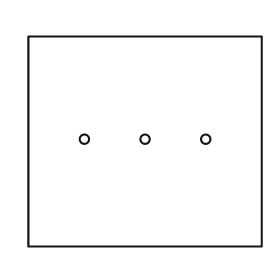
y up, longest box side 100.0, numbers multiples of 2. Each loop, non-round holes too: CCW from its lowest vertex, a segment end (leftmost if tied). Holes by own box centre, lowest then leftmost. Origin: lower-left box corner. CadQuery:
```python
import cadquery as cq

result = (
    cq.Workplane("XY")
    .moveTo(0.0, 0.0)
    .lineTo(100.0, 0.0)
    .lineTo(100.0, 90.0)
    .lineTo(0.0, 90.0)
    .close()
    .moveTo(24.0, 46.0)
    .circle(2.0)
    .moveTo(50.0, 46.0)
    .circle(2.0)
    .moveTo(76.0, 46.0)
    .circle(2.0)
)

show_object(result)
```